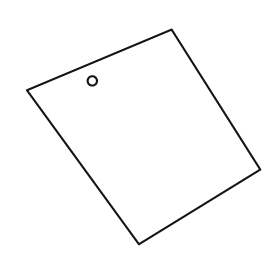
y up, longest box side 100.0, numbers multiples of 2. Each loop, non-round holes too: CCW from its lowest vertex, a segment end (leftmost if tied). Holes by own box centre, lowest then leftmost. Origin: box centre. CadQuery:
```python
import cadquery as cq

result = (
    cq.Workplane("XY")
    .moveTo(-2.0, -46.0)
    .lineTo(50.0, -14.0)
    .lineTo(12.0, 46.0)
    .lineTo(-50.0, 20.0)
    .close()
    .moveTo(-22.0, 24.0)
    .circle(2.0)
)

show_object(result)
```